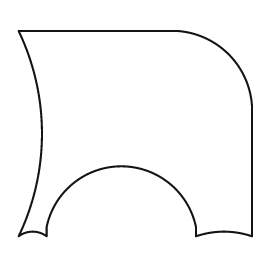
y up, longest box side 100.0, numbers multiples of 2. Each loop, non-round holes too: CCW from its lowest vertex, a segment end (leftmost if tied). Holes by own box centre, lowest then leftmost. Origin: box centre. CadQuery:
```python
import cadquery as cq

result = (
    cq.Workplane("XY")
    .moveTo(-50.0, -44.0)
    .threePointArc((-44.0, -42.0), (-38.0, -44.0))
    .lineTo(-38.0, -40.0)
    .threePointArc((-6.0, -14.0), (26.0, -40.0))
    .lineTo(26.0, -44.0)
    .threePointArc((38.0, -42.0), (50.0, -44.0))
    .lineTo(50.0, 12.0)
    .threePointArc((40.0, 34.0), (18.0, 44.0))
    .lineTo(-50.0, 44.0)
    .threePointArc((-40.0, 0.0), (-50.0, -44.0))
    .close()
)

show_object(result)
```